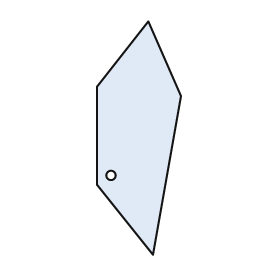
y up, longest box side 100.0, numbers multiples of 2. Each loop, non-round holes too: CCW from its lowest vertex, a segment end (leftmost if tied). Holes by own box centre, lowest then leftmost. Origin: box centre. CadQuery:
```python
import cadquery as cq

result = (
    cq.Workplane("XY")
    .moveTo(6.0, -50.0)
    .lineTo(18.0, 18.0)
    .lineTo(4.0, 50.0)
    .lineTo(-18.0, 22.0)
    .lineTo(-18.0, -20.0)
    .close()
    .moveTo(-12.0, -16.0)
    .circle(2.0)
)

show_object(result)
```